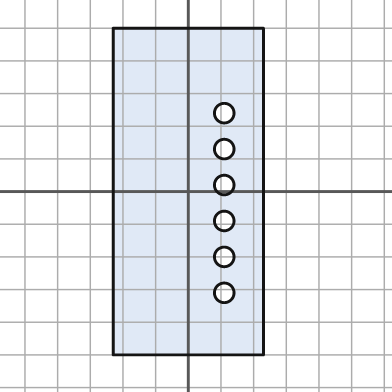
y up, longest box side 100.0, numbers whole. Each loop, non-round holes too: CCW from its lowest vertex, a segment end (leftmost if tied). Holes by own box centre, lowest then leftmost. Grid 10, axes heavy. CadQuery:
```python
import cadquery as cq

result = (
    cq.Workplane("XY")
    .moveTo(-23.0, -50.0)
    .lineTo(23.0, -50.0)
    .lineTo(23.0, 50.0)
    .lineTo(-23.0, 50.0)
    .close()
    .moveTo(11.0, -31.0)
    .circle(3.0)
    .moveTo(11.0, -20.0)
    .circle(3.0)
    .moveTo(11.0, -9.0)
    .circle(3.0)
    .moveTo(11.0, 2.0)
    .circle(3.0)
    .moveTo(11.0, 13.0)
    .circle(3.0)
    .moveTo(11.0, 24.0)
    .circle(3.0)
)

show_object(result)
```